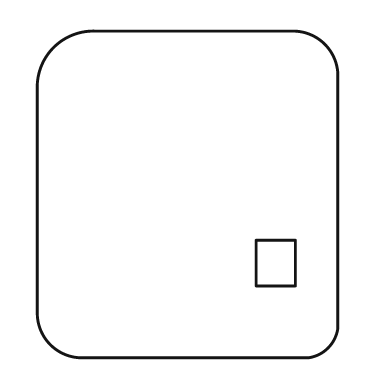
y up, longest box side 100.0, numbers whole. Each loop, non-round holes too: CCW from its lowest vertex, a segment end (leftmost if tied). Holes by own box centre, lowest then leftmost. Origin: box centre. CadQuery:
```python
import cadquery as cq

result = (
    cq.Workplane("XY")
    .moveTo(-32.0, -50.0)
    .lineTo(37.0, -50.0)
    .threePointArc((43.0, -47.0), (46.0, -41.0))
    .lineTo(46.0, 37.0)
    .threePointArc((42.0, 46.0), (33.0, 50.0))
    .lineTo(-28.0, 50.0)
    .threePointArc((-41.0, 45.0), (-46.0, 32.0))
    .lineTo(-46.0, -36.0)
    .threePointArc((-42.0, -46.0), (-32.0, -50.0))
    .close()
    .moveTo(21.0, -28.0)
    .lineTo(33.0, -28.0)
    .lineTo(33.0, -14.0)
    .lineTo(21.0, -14.0)
    .close()
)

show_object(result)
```